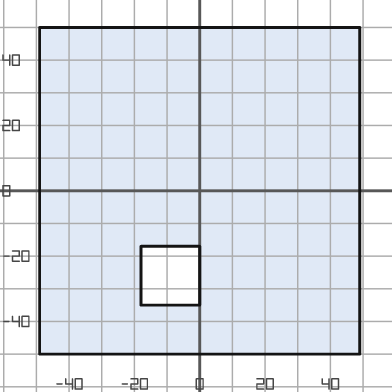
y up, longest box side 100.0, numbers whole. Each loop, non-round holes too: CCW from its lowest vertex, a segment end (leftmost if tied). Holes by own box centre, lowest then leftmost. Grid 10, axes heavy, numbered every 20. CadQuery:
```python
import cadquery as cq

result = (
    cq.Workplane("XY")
    .moveTo(-49.0, -50.0)
    .lineTo(49.0, -50.0)
    .lineTo(49.0, 50.0)
    .lineTo(-49.0, 50.0)
    .close()
    .moveTo(-18.0, -35.0)
    .lineTo(0.0, -35.0)
    .lineTo(0.0, -17.0)
    .lineTo(-18.0, -17.0)
    .close()
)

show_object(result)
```